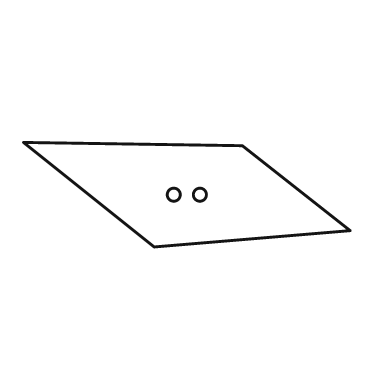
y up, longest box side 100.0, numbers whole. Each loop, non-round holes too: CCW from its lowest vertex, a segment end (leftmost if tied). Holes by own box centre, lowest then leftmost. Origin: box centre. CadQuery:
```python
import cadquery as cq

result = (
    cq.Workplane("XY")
    .moveTo(-10.0, -16.0)
    .lineTo(50.0, -11.0)
    .lineTo(17.0, 15.0)
    .lineTo(-50.0, 16.0)
    .close()
    .moveTo(-4.0, 0.0)
    .circle(2.0)
    .moveTo(4.0, 0.0)
    .circle(2.0)
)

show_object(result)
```